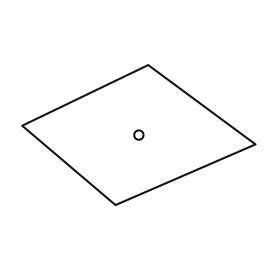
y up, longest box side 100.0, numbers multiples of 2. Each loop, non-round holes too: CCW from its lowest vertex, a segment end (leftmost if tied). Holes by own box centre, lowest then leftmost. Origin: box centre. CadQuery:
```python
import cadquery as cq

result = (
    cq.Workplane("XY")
    .moveTo(-10.0, -30.0)
    .lineTo(50.0, -4.0)
    .lineTo(4.0, 30.0)
    .lineTo(-50.0, 4.0)
    .close()
    .moveTo(0.0, 0.0)
    .circle(2.0)
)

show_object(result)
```